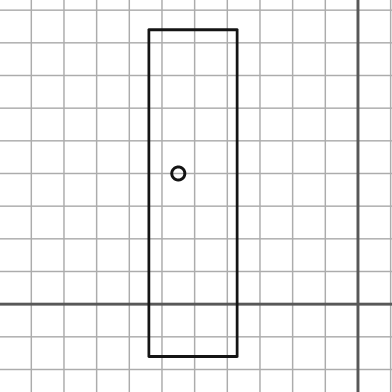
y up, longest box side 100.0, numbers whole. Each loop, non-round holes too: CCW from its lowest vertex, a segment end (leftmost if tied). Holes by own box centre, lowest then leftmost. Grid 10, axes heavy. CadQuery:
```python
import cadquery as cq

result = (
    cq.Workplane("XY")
    .moveTo(-64.0, -16.0)
    .lineTo(-37.0, -16.0)
    .lineTo(-37.0, 84.0)
    .lineTo(-64.0, 84.0)
    .close()
    .moveTo(-55.0, 40.0)
    .circle(2.0)
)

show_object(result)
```